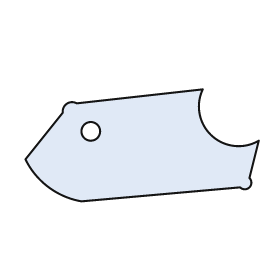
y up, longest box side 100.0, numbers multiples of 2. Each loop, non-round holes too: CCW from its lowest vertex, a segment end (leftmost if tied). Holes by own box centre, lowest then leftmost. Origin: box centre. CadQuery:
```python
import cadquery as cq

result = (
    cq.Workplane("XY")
    .moveTo(-26.0, -24.0)
    .lineTo(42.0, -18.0)
    .threePointArc((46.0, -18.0), (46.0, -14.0))
    .lineTo(50.0, 2.0)
    .threePointArc((30.0, 4.0), (26.0, 24.0))
    .lineTo(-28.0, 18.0)
    .threePointArc((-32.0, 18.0), (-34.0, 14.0))
    .lineTo(-50.0, -6.0)
    .threePointArc((-40.0, -18.0), (-26.0, -24.0))
    .close()
    .moveTo(-22.0, 6.0)
    .circle(4.0)
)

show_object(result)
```